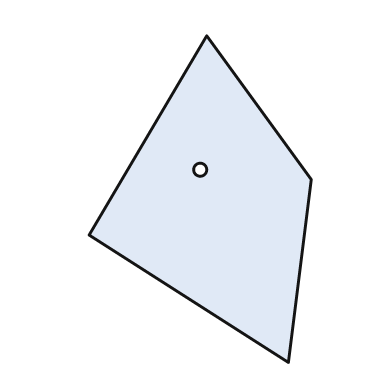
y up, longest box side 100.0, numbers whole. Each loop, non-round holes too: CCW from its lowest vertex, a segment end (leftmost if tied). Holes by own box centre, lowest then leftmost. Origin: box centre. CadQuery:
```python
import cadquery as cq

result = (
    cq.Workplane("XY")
    .moveTo(27.0, -50.0)
    .lineTo(34.0, 6.0)
    .lineTo(2.0, 50.0)
    .lineTo(-34.0, -11.0)
    .close()
    .moveTo(0.0, 9.0)
    .circle(2.0)
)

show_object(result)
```